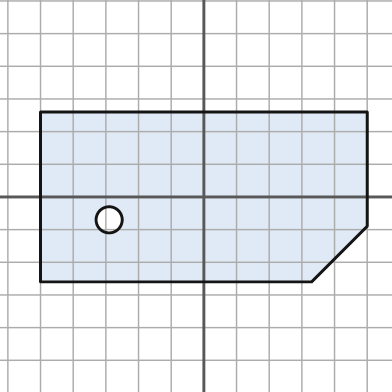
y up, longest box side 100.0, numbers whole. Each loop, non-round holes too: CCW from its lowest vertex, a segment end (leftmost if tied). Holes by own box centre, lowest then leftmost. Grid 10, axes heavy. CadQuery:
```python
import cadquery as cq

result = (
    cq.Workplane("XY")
    .moveTo(-50.0, -26.0)
    .lineTo(33.0, -26.0)
    .lineTo(50.0, -9.0)
    .lineTo(50.0, 26.0)
    .lineTo(-50.0, 26.0)
    .close()
    .moveTo(-29.0, -7.0)
    .circle(4.0)
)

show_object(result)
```